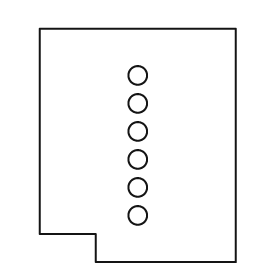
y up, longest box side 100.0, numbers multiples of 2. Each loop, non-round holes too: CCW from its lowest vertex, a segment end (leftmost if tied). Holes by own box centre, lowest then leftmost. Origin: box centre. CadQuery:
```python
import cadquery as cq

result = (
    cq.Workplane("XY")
    .moveTo(-18.0, -50.0)
    .lineTo(42.0, -50.0)
    .lineTo(42.0, 50.0)
    .lineTo(-42.0, 50.0)
    .lineTo(-42.0, -38.0)
    .lineTo(-18.0, -38.0)
    .close()
    .moveTo(0.0, -30.0)
    .circle(4.0)
    .moveTo(0.0, -18.0)
    .circle(4.0)
    .moveTo(0.0, -6.0)
    .circle(4.0)
    .moveTo(0.0, 6.0)
    .circle(4.0)
    .moveTo(0.0, 18.0)
    .circle(4.0)
    .moveTo(0.0, 30.0)
    .circle(4.0)
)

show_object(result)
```